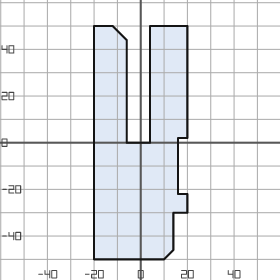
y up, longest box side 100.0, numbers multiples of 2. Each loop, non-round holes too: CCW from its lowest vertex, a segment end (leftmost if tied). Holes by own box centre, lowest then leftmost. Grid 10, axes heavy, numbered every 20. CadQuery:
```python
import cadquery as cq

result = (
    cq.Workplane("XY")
    .moveTo(-20.0, -50.0)
    .lineTo(10.0, -50.0)
    .lineTo(14.0, -46.0)
    .lineTo(14.0, -30.0)
    .lineTo(20.0, -30.0)
    .lineTo(20.0, -22.0)
    .lineTo(16.0, -22.0)
    .lineTo(16.0, 2.0)
    .lineTo(20.0, 2.0)
    .lineTo(20.0, 50.0)
    .lineTo(4.0, 50.0)
    .lineTo(4.0, 0.0)
    .lineTo(-6.0, 0.0)
    .lineTo(-6.0, 44.0)
    .lineTo(-12.0, 50.0)
    .lineTo(-20.0, 50.0)
    .close()
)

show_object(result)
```